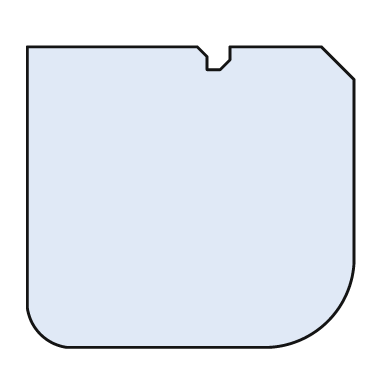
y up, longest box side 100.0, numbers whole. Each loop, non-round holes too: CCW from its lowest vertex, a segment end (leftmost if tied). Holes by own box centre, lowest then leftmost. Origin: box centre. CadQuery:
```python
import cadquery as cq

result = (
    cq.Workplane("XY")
    .moveTo(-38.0, -46.0)
    .lineTo(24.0, -46.0)
    .threePointArc((42.0, -38.0), (50.0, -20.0))
    .lineTo(50.0, 36.0)
    .lineTo(40.0, 46.0)
    .lineTo(12.0, 46.0)
    .lineTo(12.0, 42.0)
    .lineTo(9.0, 39.0)
    .lineTo(5.0, 39.0)
    .lineTo(5.0, 43.0)
    .lineTo(2.0, 46.0)
    .lineTo(-50.0, 46.0)
    .lineTo(-50.0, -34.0)
    .threePointArc((-46.0, -42.0), (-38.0, -46.0))
    .close()
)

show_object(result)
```